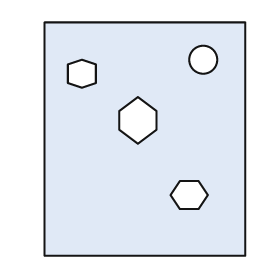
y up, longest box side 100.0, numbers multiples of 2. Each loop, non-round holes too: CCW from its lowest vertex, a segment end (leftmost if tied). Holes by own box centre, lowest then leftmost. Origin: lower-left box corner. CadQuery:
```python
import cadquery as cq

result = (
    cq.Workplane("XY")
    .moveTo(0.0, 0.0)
    .lineTo(86.0, 0.0)
    .lineTo(86.0, 100.0)
    .lineTo(0.0, 100.0)
    .close()
    .moveTo(58.0, 20.0)
    .lineTo(66.0, 20.0)
    .lineTo(70.0, 26.0)
    .lineTo(66.0, 32.0)
    .lineTo(58.0, 32.0)
    .lineTo(54.0, 26.0)
    .close()
    .moveTo(40.0, 48.0)
    .lineTo(48.0, 54.0)
    .lineTo(48.0, 62.0)
    .lineTo(40.0, 68.0)
    .lineTo(32.0, 62.0)
    .lineTo(32.0, 54.0)
    .close()
    .moveTo(16.0, 72.0)
    .lineTo(22.0, 74.0)
    .lineTo(22.0, 82.0)
    .lineTo(16.0, 84.0)
    .lineTo(10.0, 82.0)
    .lineTo(10.0, 74.0)
    .close()
    .moveTo(68.0, 84.0)
    .circle(6.0)
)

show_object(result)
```